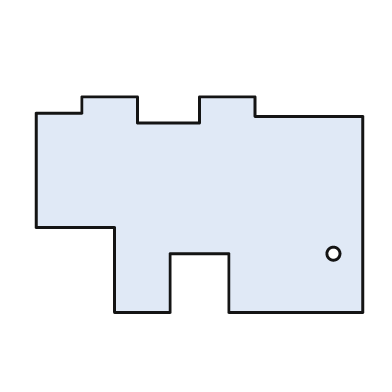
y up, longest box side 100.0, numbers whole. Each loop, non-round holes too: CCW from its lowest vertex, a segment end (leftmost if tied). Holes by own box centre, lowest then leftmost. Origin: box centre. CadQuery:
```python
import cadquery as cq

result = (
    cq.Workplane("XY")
    .moveTo(-26.0, -33.0)
    .lineTo(-9.0, -33.0)
    .lineTo(-9.0, -15.0)
    .lineTo(9.0, -15.0)
    .lineTo(9.0, -33.0)
    .lineTo(50.0, -33.0)
    .lineTo(50.0, 27.0)
    .lineTo(17.0, 27.0)
    .lineTo(17.0, 33.0)
    .lineTo(0.0, 33.0)
    .lineTo(0.0, 25.0)
    .lineTo(-19.0, 25.0)
    .lineTo(-19.0, 33.0)
    .lineTo(-36.0, 33.0)
    .lineTo(-36.0, 28.0)
    .lineTo(-50.0, 28.0)
    .lineTo(-50.0, -7.0)
    .lineTo(-26.0, -7.0)
    .close()
    .moveTo(41.0, -15.0)
    .circle(2.0)
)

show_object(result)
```